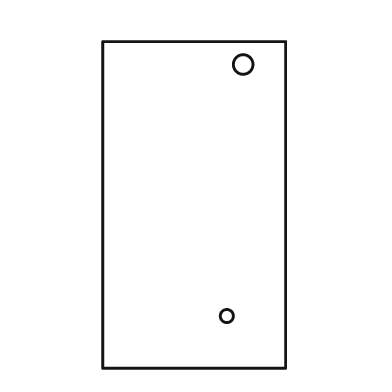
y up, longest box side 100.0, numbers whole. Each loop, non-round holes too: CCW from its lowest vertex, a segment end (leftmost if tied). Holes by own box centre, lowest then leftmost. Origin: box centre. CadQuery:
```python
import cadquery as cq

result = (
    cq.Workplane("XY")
    .moveTo(-28.0, -50.0)
    .lineTo(28.0, -50.0)
    .lineTo(28.0, 50.0)
    .lineTo(-28.0, 50.0)
    .close()
    .moveTo(10.0, -34.0)
    .circle(2.0)
    .moveTo(15.0, 43.0)
    .circle(3.0)
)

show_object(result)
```